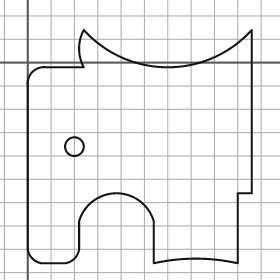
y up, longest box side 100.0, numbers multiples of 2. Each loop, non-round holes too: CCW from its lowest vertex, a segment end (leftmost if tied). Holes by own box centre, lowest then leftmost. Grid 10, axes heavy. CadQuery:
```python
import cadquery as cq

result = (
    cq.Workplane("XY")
    .moveTo(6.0, -86.0)
    .lineTo(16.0, -86.0)
    .threePointArc((20.0, -84.0), (22.0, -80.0))
    .lineTo(22.0, -68.0)
    .threePointArc((38.0, -56.0), (54.0, -68.0))
    .lineTo(54.0, -86.0)
    .threePointArc((72.0, -84.0), (90.0, -86.0))
    .lineTo(90.0, -56.0)
    .lineTo(96.0, -56.0)
    .lineTo(96.0, 14.0)
    .threePointArc((60.0, -2.0), (24.0, 14.0))
    .threePointArc((22.0, 6.0), (24.0, -2.0))
    .lineTo(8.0, -2.0)
    .threePointArc((2.0, -4.0), (0.0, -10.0))
    .lineTo(0.0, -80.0)
    .threePointArc((2.0, -84.0), (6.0, -86.0))
    .close()
    .moveTo(20.0, -36.0)
    .circle(4.0)
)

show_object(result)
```